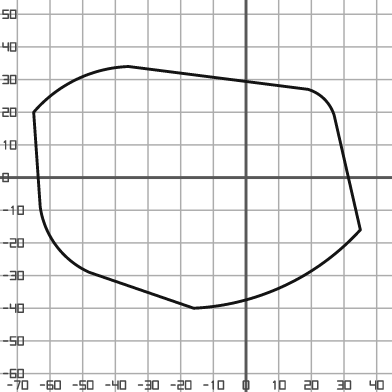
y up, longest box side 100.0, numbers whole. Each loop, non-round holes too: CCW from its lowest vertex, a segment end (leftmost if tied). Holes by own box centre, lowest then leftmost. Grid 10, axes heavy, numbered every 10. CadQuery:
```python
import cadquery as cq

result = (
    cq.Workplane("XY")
    .moveTo(-16.0, -40.0)
    .threePointArc((12.0, -33.0), (35.0, -16.0))
    .lineTo(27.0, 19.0)
    .threePointArc((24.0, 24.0), (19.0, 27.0))
    .lineTo(-36.0, 34.0)
    .threePointArc((-52.0, 30.0), (-65.0, 20.0))
    .lineTo(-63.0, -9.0)
    .threePointArc((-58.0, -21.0), (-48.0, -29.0))
    .close()
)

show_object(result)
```